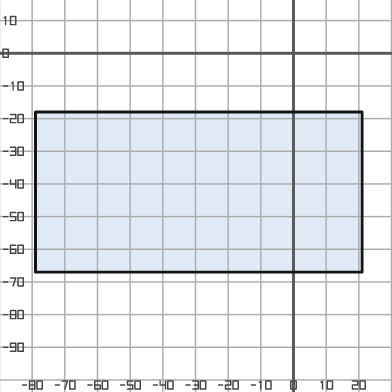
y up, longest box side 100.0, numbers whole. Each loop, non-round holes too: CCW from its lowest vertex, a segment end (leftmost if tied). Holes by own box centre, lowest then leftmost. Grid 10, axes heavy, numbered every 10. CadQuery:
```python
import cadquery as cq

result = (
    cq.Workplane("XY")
    .moveTo(-79.0, -67.0)
    .lineTo(21.0, -67.0)
    .lineTo(21.0, -18.0)
    .lineTo(-79.0, -18.0)
    .close()
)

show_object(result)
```